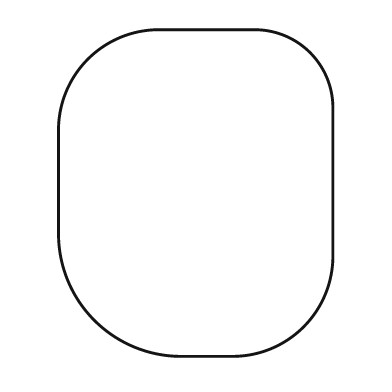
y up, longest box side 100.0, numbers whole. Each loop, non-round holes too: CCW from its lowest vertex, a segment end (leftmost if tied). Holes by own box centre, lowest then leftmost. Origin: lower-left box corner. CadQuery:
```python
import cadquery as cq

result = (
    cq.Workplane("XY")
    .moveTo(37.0, 0.0)
    .lineTo(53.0, 0.0)
    .threePointArc((75.0, 9.0), (84.0, 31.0))
    .lineTo(84.0, 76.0)
    .threePointArc((77.0, 93.0), (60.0, 100.0))
    .lineTo(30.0, 100.0)
    .threePointArc((9.0, 91.0), (0.0, 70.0))
    .lineTo(0.0, 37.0)
    .threePointArc((11.0, 11.0), (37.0, 0.0))
    .close()
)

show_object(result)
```